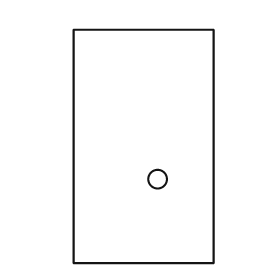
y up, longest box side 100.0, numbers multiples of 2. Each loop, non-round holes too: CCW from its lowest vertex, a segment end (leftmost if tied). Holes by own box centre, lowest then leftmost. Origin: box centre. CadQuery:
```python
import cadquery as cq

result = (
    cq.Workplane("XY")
    .moveTo(-30.0, -50.0)
    .lineTo(30.0, -50.0)
    .lineTo(30.0, 50.0)
    .lineTo(-30.0, 50.0)
    .close()
    .moveTo(6.0, -14.0)
    .circle(4.0)
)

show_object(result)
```